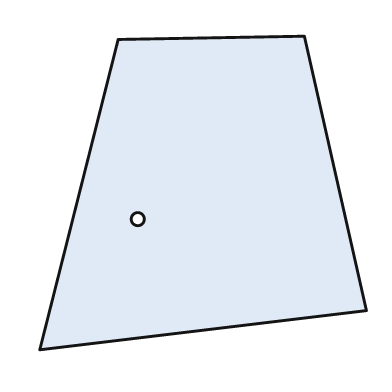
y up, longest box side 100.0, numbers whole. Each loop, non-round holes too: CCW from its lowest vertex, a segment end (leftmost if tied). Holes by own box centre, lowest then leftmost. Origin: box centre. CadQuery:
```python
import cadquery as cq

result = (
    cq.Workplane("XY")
    .moveTo(-50.0, -48.0)
    .lineTo(50.0, -36.0)
    .lineTo(31.0, 48.0)
    .lineTo(-26.0, 47.0)
    .close()
    .moveTo(-20.0, -8.0)
    .circle(2.0)
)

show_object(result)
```